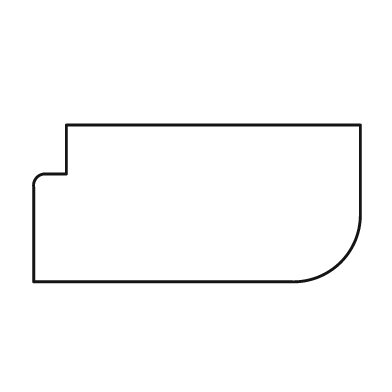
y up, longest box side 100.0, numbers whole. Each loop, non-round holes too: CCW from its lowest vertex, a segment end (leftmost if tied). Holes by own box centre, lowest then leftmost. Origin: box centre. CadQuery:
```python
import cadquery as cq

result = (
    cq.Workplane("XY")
    .moveTo(-50.0, -24.0)
    .lineTo(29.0, -24.0)
    .threePointArc((44.0, -18.0), (50.0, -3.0))
    .lineTo(50.0, 24.0)
    .lineTo(-40.0, 24.0)
    .lineTo(-40.0, 9.0)
    .lineTo(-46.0, 9.0)
    .threePointArc((-49.0, 8.0), (-50.0, 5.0))
    .close()
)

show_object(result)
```